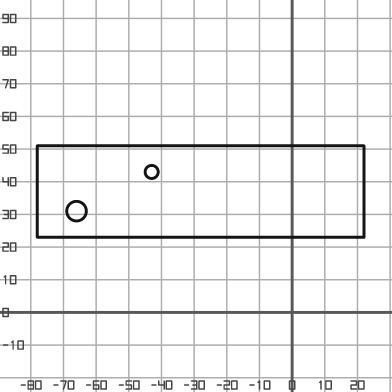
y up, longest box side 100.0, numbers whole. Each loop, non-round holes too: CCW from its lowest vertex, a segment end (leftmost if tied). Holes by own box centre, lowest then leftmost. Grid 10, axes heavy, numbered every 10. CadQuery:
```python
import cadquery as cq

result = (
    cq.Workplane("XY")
    .moveTo(-78.0, 23.0)
    .lineTo(22.0, 23.0)
    .lineTo(22.0, 51.0)
    .lineTo(-78.0, 51.0)
    .close()
    .moveTo(-66.0, 31.0)
    .circle(3.0)
    .moveTo(-43.0, 43.0)
    .circle(2.0)
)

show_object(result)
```